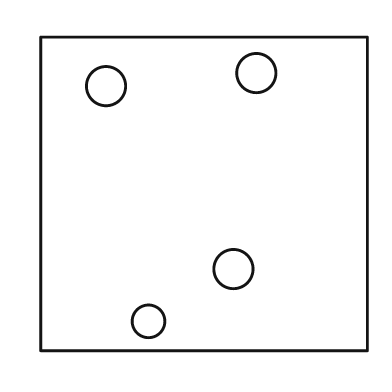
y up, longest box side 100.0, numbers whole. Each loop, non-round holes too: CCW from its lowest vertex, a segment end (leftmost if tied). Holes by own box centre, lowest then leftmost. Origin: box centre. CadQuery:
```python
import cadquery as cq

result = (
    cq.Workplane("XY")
    .moveTo(-50.0, -48.0)
    .lineTo(50.0, -48.0)
    .lineTo(50.0, 48.0)
    .lineTo(-50.0, 48.0)
    .close()
    .moveTo(-17.0, -39.0)
    .circle(5.0)
    .moveTo(9.0, -23.0)
    .circle(6.0)
    .moveTo(-30.0, 33.0)
    .circle(6.0)
    .moveTo(16.0, 37.0)
    .circle(6.0)
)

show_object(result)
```